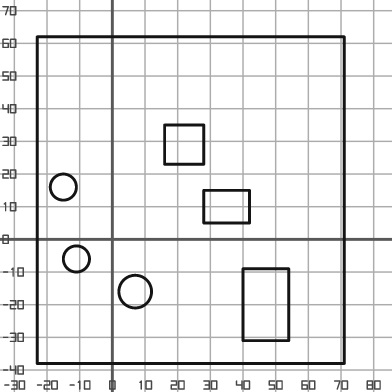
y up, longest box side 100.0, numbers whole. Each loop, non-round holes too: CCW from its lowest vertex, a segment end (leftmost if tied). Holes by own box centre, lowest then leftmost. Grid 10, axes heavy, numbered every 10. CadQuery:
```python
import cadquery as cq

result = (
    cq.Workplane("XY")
    .moveTo(-23.0, -38.0)
    .lineTo(71.0, -38.0)
    .lineTo(71.0, 62.0)
    .lineTo(-23.0, 62.0)
    .close()
    .moveTo(40.0, -31.0)
    .lineTo(54.0, -31.0)
    .lineTo(54.0, -9.0)
    .lineTo(40.0, -9.0)
    .close()
    .moveTo(7.0, -16.0)
    .circle(5.0)
    .moveTo(-11.0, -6.0)
    .circle(4.0)
    .moveTo(28.0, 5.0)
    .lineTo(42.0, 5.0)
    .lineTo(42.0, 15.0)
    .lineTo(28.0, 15.0)
    .close()
    .moveTo(-15.0, 16.0)
    .circle(4.0)
    .moveTo(16.0, 23.0)
    .lineTo(28.0, 23.0)
    .lineTo(28.0, 35.0)
    .lineTo(16.0, 35.0)
    .close()
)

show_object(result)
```